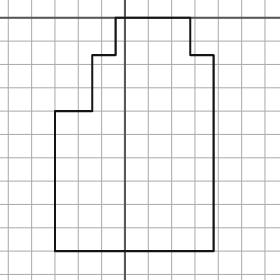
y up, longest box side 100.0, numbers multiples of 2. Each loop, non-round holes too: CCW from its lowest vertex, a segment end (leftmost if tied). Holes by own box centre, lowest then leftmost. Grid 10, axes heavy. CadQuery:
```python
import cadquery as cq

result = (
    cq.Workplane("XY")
    .moveTo(-30.0, -100.0)
    .lineTo(38.0, -100.0)
    .lineTo(38.0, -16.0)
    .lineTo(28.0, -16.0)
    .lineTo(28.0, 0.0)
    .lineTo(-4.0, 0.0)
    .lineTo(-4.0, -16.0)
    .lineTo(-14.0, -16.0)
    .lineTo(-14.0, -40.0)
    .lineTo(-30.0, -40.0)
    .close()
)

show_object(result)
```